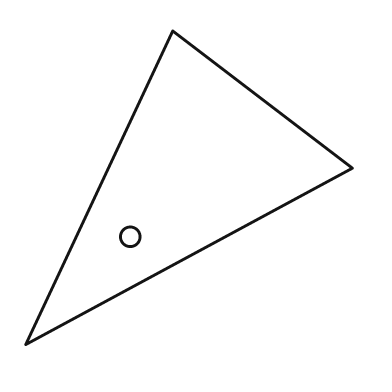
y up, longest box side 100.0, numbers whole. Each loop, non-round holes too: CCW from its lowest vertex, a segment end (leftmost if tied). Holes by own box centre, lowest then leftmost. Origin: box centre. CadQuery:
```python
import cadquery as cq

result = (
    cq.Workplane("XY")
    .moveTo(-50.0, -48.0)
    .lineTo(50.0, 6.0)
    .lineTo(-5.0, 48.0)
    .close()
    .moveTo(-18.0, -15.0)
    .circle(3.0)
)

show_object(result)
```